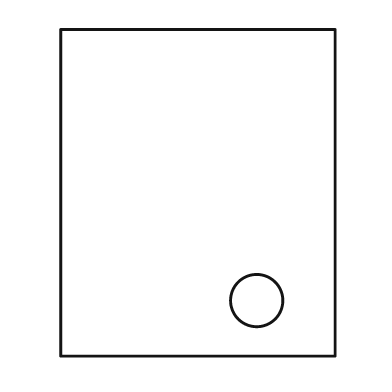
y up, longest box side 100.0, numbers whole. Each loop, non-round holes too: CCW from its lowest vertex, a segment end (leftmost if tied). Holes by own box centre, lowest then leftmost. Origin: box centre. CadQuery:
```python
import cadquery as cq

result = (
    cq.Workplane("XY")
    .moveTo(-42.0, -50.0)
    .lineTo(42.0, -50.0)
    .lineTo(42.0, 50.0)
    .lineTo(-42.0, 50.0)
    .close()
    .moveTo(18.0, -33.0)
    .circle(8.0)
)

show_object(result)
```